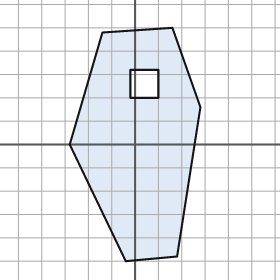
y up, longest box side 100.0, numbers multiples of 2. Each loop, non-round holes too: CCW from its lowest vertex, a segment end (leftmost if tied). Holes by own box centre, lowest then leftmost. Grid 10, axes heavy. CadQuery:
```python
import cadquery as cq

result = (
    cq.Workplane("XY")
    .moveTo(-4.0, -50.0)
    .lineTo(18.0, -48.0)
    .lineTo(28.0, 16.0)
    .lineTo(16.0, 50.0)
    .lineTo(-14.0, 48.0)
    .lineTo(-28.0, 0.0)
    .close()
    .moveTo(-2.0, 20.0)
    .lineTo(10.0, 20.0)
    .lineTo(10.0, 32.0)
    .lineTo(-2.0, 32.0)
    .close()
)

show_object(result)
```